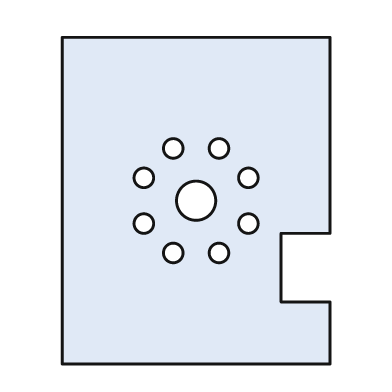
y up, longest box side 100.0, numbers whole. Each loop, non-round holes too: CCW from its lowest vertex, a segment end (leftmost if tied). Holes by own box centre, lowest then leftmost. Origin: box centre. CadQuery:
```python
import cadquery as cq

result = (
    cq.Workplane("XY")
    .moveTo(-41.0, -50.0)
    .lineTo(41.0, -50.0)
    .lineTo(41.0, -31.0)
    .lineTo(26.0, -31.0)
    .lineTo(26.0, -10.0)
    .lineTo(41.0, -10.0)
    .lineTo(41.0, 50.0)
    .lineTo(-41.0, 50.0)
    .close()
    .moveTo(-7.0, -16.0)
    .circle(3.0)
    .moveTo(7.0, -16.0)
    .circle(3.0)
    .moveTo(-16.0, -7.0)
    .circle(3.0)
    .moveTo(16.0, -7.0)
    .circle(3.0)
    .moveTo(0.0, 0.0)
    .circle(6.0)
    .moveTo(-16.0, 7.0)
    .circle(3.0)
    .moveTo(16.0, 7.0)
    .circle(3.0)
    .moveTo(-7.0, 16.0)
    .circle(3.0)
    .moveTo(7.0, 16.0)
    .circle(3.0)
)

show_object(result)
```